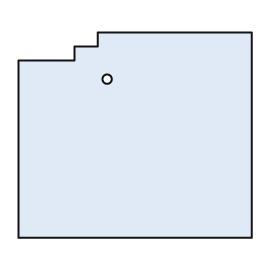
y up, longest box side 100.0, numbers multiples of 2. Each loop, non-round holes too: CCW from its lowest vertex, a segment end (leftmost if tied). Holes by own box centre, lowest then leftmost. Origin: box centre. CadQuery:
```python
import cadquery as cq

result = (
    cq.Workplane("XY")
    .moveTo(-50.0, -44.0)
    .lineTo(50.0, -44.0)
    .lineTo(50.0, 44.0)
    .lineTo(-16.0, 44.0)
    .lineTo(-16.0, 38.0)
    .lineTo(-26.0, 38.0)
    .lineTo(-26.0, 32.0)
    .lineTo(-50.0, 32.0)
    .close()
    .moveTo(-12.0, 24.0)
    .circle(2.0)
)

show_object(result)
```